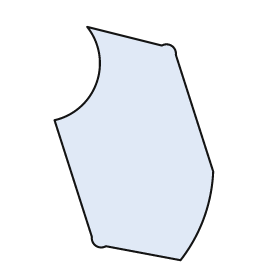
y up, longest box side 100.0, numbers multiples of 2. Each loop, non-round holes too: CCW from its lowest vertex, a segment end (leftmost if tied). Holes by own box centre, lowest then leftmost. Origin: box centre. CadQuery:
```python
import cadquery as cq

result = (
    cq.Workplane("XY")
    .moveTo(20.0, -50.0)
    .threePointArc((30.0, -32.0), (34.0, -12.0))
    .lineTo(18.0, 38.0)
    .threePointArc((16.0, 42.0), (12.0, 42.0))
    .lineTo(-20.0, 50.0)
    .threePointArc((-16.0, 26.0), (-34.0, 10.0))
    .lineTo(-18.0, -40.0)
    .threePointArc((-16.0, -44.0), (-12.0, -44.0))
    .close()
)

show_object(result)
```